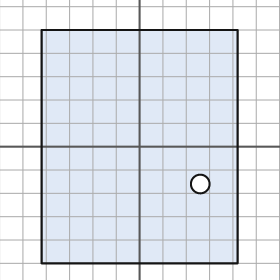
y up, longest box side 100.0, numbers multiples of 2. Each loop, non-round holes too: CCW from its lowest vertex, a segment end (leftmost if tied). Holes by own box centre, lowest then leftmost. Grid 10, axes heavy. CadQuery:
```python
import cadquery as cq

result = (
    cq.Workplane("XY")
    .moveTo(-42.0, -50.0)
    .lineTo(42.0, -50.0)
    .lineTo(42.0, 50.0)
    .lineTo(-42.0, 50.0)
    .close()
    .moveTo(26.0, -16.0)
    .circle(4.0)
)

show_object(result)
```